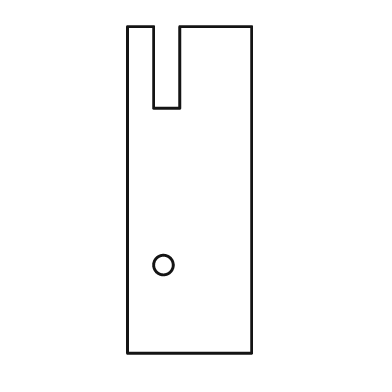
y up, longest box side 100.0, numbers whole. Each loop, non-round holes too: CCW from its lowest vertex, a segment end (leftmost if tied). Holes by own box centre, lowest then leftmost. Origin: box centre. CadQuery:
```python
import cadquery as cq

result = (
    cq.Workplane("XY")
    .moveTo(-19.0, -50.0)
    .lineTo(19.0, -50.0)
    .lineTo(19.0, 50.0)
    .lineTo(-3.0, 50.0)
    .lineTo(-3.0, 25.0)
    .lineTo(-11.0, 25.0)
    .lineTo(-11.0, 50.0)
    .lineTo(-19.0, 50.0)
    .close()
    .moveTo(-8.0, -23.0)
    .circle(3.0)
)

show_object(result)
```